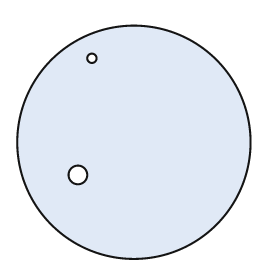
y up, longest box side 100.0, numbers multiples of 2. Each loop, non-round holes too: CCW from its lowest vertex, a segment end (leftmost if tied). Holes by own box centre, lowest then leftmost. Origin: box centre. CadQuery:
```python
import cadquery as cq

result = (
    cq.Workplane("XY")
    .moveTo(0.0, 0.0)
    .circle(50.0)
    .moveTo(-24.0, -14.0)
    .circle(4.0)
    .moveTo(-18.0, 36.0)
    .circle(2.0)
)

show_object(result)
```